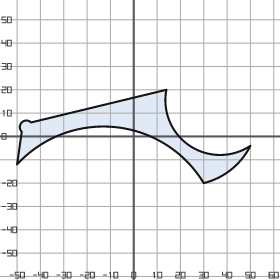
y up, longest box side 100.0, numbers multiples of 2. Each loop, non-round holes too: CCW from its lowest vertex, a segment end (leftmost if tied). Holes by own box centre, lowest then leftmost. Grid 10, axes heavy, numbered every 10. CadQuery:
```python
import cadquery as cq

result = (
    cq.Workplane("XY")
    .moveTo(30.0, -20.0)
    .threePointArc((42.0, -14.0), (50.0, -4.0))
    .threePointArc((24.0, -4.0), (14.0, 20.0))
    .lineTo(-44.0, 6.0)
    .threePointArc((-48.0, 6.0), (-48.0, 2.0))
    .lineTo(-50.0, -12.0)
    .threePointArc((-8.0, 4.0), (30.0, -20.0))
    .close()
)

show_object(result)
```